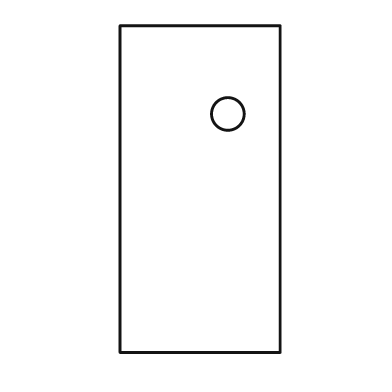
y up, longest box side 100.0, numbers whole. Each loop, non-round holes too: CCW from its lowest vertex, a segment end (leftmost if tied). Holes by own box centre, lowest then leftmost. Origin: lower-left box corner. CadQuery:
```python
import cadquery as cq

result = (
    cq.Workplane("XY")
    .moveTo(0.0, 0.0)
    .lineTo(49.0, 0.0)
    .lineTo(49.0, 100.0)
    .lineTo(0.0, 100.0)
    .close()
    .moveTo(33.0, 73.0)
    .circle(5.0)
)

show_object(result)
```